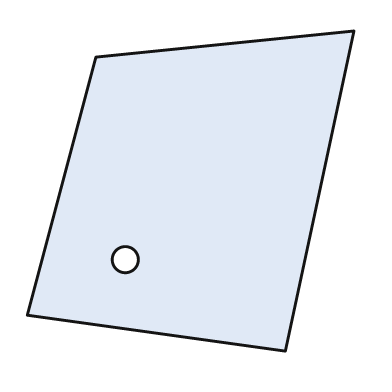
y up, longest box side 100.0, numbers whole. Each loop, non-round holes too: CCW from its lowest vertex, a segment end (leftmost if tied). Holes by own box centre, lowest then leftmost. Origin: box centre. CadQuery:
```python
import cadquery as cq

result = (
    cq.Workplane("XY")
    .moveTo(29.0, -49.0)
    .lineTo(50.0, 49.0)
    .lineTo(-29.0, 41.0)
    .lineTo(-50.0, -38.0)
    .close()
    .moveTo(-20.0, -21.0)
    .circle(4.0)
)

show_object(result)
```